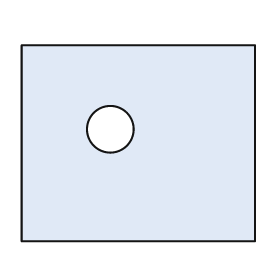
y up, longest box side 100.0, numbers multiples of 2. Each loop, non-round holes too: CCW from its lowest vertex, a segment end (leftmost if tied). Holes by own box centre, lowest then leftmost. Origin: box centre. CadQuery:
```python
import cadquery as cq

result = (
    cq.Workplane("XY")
    .moveTo(-50.0, -42.0)
    .lineTo(50.0, -42.0)
    .lineTo(50.0, 42.0)
    .lineTo(-50.0, 42.0)
    .close()
    .moveTo(-12.0, 6.0)
    .circle(10.0)
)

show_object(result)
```